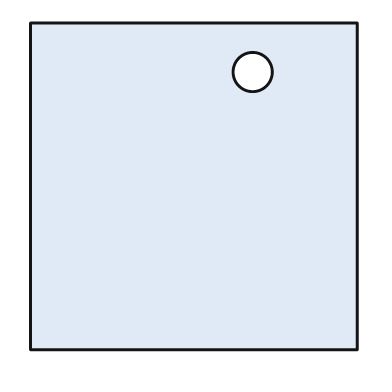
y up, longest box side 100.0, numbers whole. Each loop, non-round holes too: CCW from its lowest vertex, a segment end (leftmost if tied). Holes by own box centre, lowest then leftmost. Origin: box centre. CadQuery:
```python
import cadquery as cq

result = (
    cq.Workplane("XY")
    .moveTo(-50.0, -50.0)
    .lineTo(50.0, -50.0)
    .lineTo(50.0, 50.0)
    .lineTo(-50.0, 50.0)
    .close()
    .moveTo(18.0, 35.0)
    .circle(6.0)
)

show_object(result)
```